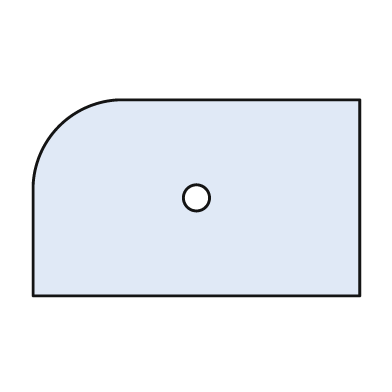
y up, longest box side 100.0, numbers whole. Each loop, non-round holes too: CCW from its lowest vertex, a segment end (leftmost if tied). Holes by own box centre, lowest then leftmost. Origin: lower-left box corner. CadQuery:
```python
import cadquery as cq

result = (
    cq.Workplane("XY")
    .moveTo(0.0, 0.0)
    .lineTo(100.0, 0.0)
    .lineTo(100.0, 60.0)
    .lineTo(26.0, 60.0)
    .threePointArc((8.0, 52.0), (0.0, 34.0))
    .close()
    .moveTo(50.0, 30.0)
    .circle(4.0)
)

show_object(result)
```